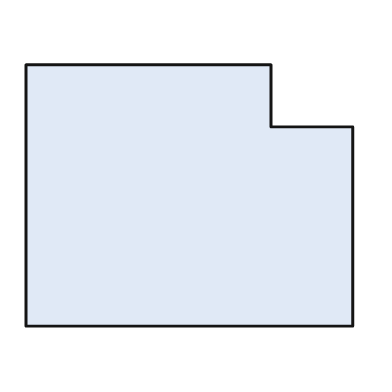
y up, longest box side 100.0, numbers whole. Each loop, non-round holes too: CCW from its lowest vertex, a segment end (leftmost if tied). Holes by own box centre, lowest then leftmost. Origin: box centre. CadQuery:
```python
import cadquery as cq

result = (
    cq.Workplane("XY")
    .moveTo(-50.0, -40.0)
    .lineTo(50.0, -40.0)
    .lineTo(50.0, 21.0)
    .lineTo(25.0, 21.0)
    .lineTo(25.0, 40.0)
    .lineTo(-50.0, 40.0)
    .close()
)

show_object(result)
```